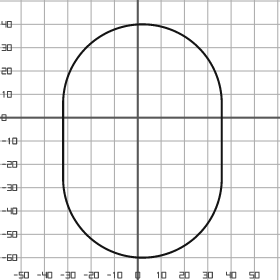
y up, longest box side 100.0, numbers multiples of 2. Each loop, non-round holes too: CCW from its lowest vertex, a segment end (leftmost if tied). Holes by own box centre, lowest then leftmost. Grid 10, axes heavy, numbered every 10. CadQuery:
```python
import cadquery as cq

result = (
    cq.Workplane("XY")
    .moveTo(-32.0, -26.0)
    .threePointArc((2.0, -60.0), (36.0, -26.0))
    .lineTo(36.0, 6.0)
    .threePointArc((2.0, 40.0), (-32.0, 6.0))
    .close()
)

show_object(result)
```